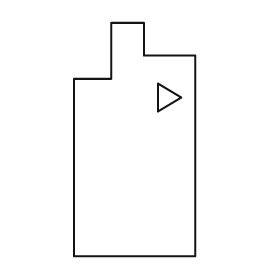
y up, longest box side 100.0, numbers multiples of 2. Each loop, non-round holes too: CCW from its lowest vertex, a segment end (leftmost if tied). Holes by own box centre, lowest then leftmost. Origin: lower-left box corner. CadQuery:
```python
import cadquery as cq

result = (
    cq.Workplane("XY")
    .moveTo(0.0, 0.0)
    .lineTo(52.0, 0.0)
    .lineTo(52.0, 86.0)
    .lineTo(30.0, 86.0)
    .lineTo(30.0, 100.0)
    .lineTo(16.0, 100.0)
    .lineTo(16.0, 76.0)
    .lineTo(0.0, 76.0)
    .close()
    .moveTo(36.0, 62.0)
    .lineTo(46.0, 68.0)
    .lineTo(36.0, 74.0)
    .close()
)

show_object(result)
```